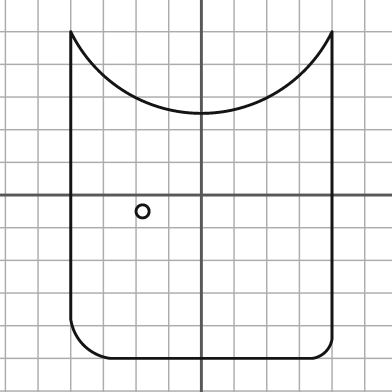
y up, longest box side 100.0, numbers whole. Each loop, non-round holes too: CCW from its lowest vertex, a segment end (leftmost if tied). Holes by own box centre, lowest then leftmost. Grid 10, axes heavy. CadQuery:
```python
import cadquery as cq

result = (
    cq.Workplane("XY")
    .moveTo(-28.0, -50.0)
    .lineTo(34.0, -50.0)
    .threePointArc((38.0, -48.0), (40.0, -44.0))
    .lineTo(40.0, 50.0)
    .threePointArc((0.0, 25.0), (-40.0, 50.0))
    .lineTo(-40.0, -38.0)
    .threePointArc((-36.0, -46.0), (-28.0, -50.0))
    .close()
    .moveTo(-18.0, -5.0)
    .circle(2.0)
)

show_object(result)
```